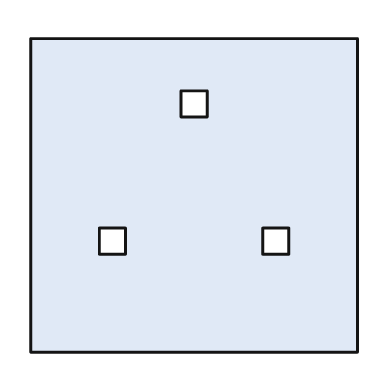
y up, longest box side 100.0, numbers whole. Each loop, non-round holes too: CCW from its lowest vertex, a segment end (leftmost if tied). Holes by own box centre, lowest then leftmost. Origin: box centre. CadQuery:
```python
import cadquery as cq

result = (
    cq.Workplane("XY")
    .moveTo(-50.0, -48.0)
    .lineTo(50.0, -48.0)
    .lineTo(50.0, 48.0)
    .lineTo(-50.0, 48.0)
    .close()
    .moveTo(-29.0, -18.0)
    .lineTo(-21.0, -18.0)
    .lineTo(-21.0, -10.0)
    .lineTo(-29.0, -10.0)
    .close()
    .moveTo(21.0, -18.0)
    .lineTo(29.0, -18.0)
    .lineTo(29.0, -10.0)
    .lineTo(21.0, -10.0)
    .close()
    .moveTo(-4.0, 24.0)
    .lineTo(4.0, 24.0)
    .lineTo(4.0, 32.0)
    .lineTo(-4.0, 32.0)
    .close()
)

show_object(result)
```